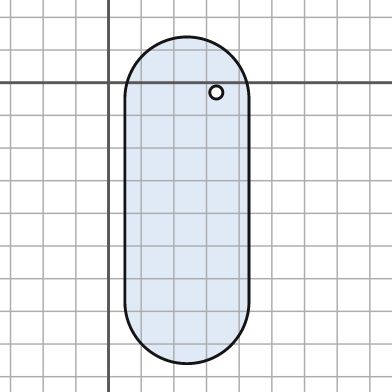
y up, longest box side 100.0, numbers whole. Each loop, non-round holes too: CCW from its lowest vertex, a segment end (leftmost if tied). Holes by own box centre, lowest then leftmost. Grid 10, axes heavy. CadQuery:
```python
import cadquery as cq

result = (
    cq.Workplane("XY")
    .moveTo(5.0, -67.0)
    .threePointArc((24.0, -86.0), (43.0, -67.0))
    .lineTo(43.0, -5.0)
    .threePointArc((24.0, 14.0), (5.0, -5.0))
    .close()
    .moveTo(33.0, -3.0)
    .circle(2.0)
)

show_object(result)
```